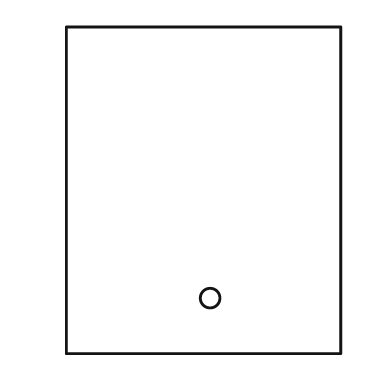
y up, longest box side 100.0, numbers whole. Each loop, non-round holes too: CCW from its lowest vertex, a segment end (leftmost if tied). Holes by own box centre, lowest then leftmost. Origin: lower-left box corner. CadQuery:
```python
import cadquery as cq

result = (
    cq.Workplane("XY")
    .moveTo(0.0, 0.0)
    .lineTo(84.0, 0.0)
    .lineTo(84.0, 100.0)
    .lineTo(0.0, 100.0)
    .close()
    .moveTo(44.0, 17.0)
    .circle(3.0)
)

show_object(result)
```